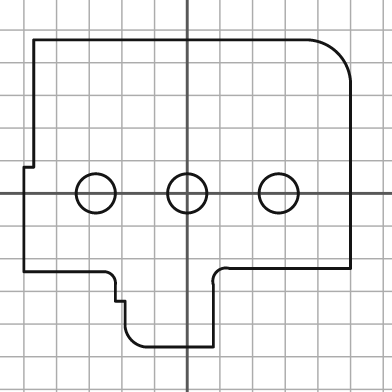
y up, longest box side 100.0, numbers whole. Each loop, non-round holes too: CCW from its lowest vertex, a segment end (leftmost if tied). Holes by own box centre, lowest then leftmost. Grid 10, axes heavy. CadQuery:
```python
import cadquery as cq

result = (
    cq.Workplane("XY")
    .moveTo(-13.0, -47.0)
    .lineTo(8.0, -47.0)
    .lineTo(8.0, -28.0)
    .threePointArc((9.0, -24.0), (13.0, -23.0))
    .lineTo(50.0, -23.0)
    .lineTo(50.0, 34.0)
    .threePointArc((46.0, 43.0), (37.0, 47.0))
    .lineTo(-47.0, 47.0)
    .lineTo(-47.0, 8.0)
    .lineTo(-50.0, 8.0)
    .lineTo(-50.0, -24.0)
    .lineTo(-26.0, -24.0)
    .threePointArc((-23.0, -25.0), (-22.0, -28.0))
    .lineTo(-22.0, -33.0)
    .lineTo(-19.0, -33.0)
    .lineTo(-19.0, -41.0)
    .threePointArc((-17.0, -45.0), (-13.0, -47.0))
    .close()
    .moveTo(-28.0, 0.0)
    .circle(6.0)
    .moveTo(0.0, 0.0)
    .circle(6.0)
    .moveTo(28.0, 0.0)
    .circle(6.0)
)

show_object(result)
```